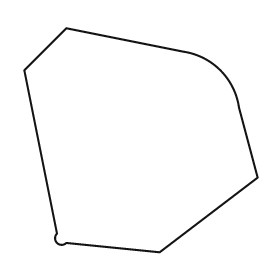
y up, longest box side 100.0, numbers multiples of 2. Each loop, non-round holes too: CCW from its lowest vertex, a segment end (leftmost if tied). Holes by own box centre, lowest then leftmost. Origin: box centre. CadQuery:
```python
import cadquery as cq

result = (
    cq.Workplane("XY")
    .moveTo(8.0, -48.0)
    .lineTo(50.0, -16.0)
    .lineTo(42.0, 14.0)
    .threePointArc((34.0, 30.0), (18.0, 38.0))
    .lineTo(-32.0, 48.0)
    .lineTo(-50.0, 30.0)
    .lineTo(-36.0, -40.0)
    .threePointArc((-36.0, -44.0), (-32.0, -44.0))
    .close()
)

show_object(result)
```